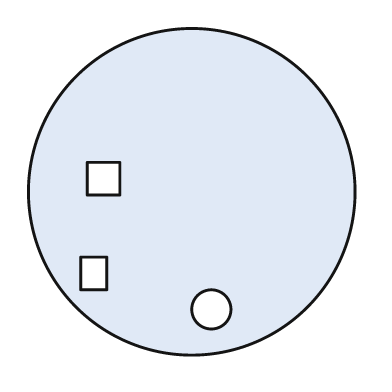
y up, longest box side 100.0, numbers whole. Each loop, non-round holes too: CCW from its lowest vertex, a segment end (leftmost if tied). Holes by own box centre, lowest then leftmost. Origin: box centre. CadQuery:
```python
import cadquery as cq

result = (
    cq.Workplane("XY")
    .moveTo(0.0, 0.0)
    .circle(50.0)
    .moveTo(6.0, -36.0)
    .circle(6.0)
    .moveTo(-34.0, -30.0)
    .lineTo(-26.0, -30.0)
    .lineTo(-26.0, -20.0)
    .lineTo(-34.0, -20.0)
    .close()
    .moveTo(-32.0, -1.0)
    .lineTo(-22.0, -1.0)
    .lineTo(-22.0, 9.0)
    .lineTo(-32.0, 9.0)
    .close()
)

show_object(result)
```